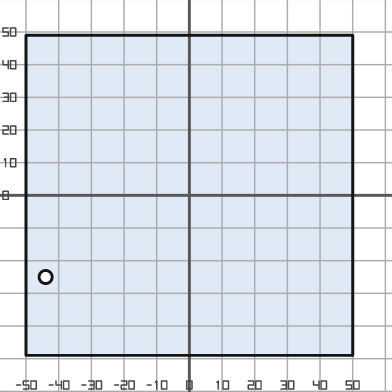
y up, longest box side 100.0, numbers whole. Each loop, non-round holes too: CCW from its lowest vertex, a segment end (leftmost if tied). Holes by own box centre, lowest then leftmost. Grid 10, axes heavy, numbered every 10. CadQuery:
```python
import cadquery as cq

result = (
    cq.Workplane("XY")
    .moveTo(-50.0, -49.0)
    .lineTo(50.0, -49.0)
    .lineTo(50.0, 49.0)
    .lineTo(-50.0, 49.0)
    .close()
    .moveTo(-44.0, -25.0)
    .circle(2.0)
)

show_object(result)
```